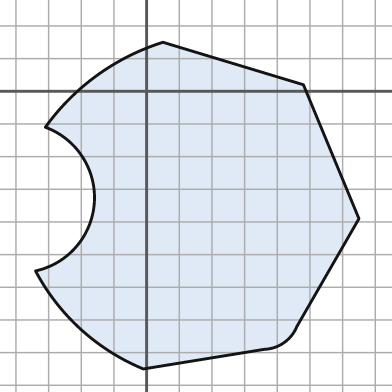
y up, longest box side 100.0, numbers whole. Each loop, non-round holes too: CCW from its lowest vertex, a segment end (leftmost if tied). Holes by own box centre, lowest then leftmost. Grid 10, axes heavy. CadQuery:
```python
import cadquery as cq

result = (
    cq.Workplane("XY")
    .moveTo(-1.0, -85.0)
    .lineTo(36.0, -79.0)
    .threePointArc((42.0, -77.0), (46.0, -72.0))
    .lineTo(65.0, -39.0)
    .lineTo(48.0, 2.0)
    .lineTo(5.0, 15.0)
    .threePointArc((-15.0, 5.0), (-31.0, -11.0))
    .threePointArc((-16.0, -34.0), (-34.0, -55.0))
    .threePointArc((-20.0, -73.0), (-1.0, -85.0))
    .close()
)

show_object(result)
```